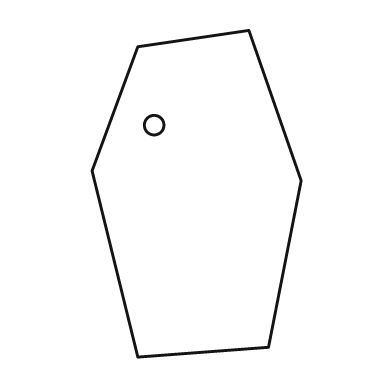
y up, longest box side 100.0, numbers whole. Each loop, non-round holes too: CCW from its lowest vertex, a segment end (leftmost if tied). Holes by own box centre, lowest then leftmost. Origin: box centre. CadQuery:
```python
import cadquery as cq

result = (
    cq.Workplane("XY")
    .moveTo(-18.0, -50.0)
    .lineTo(22.0, -47.0)
    .lineTo(32.0, 4.0)
    .lineTo(16.0, 50.0)
    .lineTo(-18.0, 45.0)
    .lineTo(-32.0, 7.0)
    .close()
    .moveTo(-13.0, 21.0)
    .circle(3.0)
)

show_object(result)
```